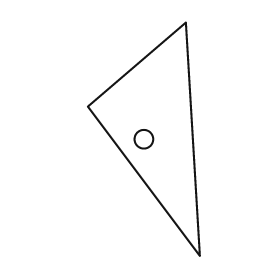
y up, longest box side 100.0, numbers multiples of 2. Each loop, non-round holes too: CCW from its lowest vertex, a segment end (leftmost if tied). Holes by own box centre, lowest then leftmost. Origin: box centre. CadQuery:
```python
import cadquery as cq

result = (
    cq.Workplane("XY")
    .moveTo(24.0, -50.0)
    .lineTo(18.0, 50.0)
    .lineTo(-24.0, 14.0)
    .close()
    .moveTo(0.0, 0.0)
    .circle(4.0)
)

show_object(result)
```